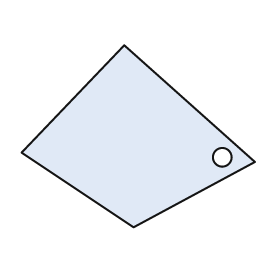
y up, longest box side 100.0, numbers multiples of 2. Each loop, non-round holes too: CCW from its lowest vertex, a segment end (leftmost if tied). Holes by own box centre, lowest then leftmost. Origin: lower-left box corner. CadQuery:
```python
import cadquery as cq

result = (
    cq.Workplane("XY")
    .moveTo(48.0, 0.0)
    .lineTo(100.0, 28.0)
    .lineTo(44.0, 78.0)
    .lineTo(0.0, 32.0)
    .close()
    .moveTo(86.0, 30.0)
    .circle(4.0)
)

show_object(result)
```